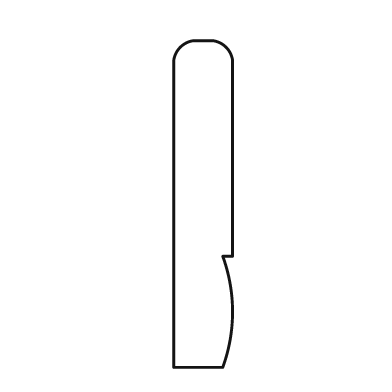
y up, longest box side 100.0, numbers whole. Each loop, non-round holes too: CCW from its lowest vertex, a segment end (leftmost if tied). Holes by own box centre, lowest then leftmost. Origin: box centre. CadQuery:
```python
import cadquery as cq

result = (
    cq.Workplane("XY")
    .moveTo(-9.0, -50.0)
    .lineTo(6.0, -50.0)
    .threePointArc((9.0, -33.0), (6.0, -16.0))
    .lineTo(9.0, -16.0)
    .lineTo(9.0, 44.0)
    .threePointArc((7.0, 48.0), (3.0, 50.0))
    .lineTo(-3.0, 50.0)
    .threePointArc((-7.0, 48.0), (-9.0, 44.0))
    .close()
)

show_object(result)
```